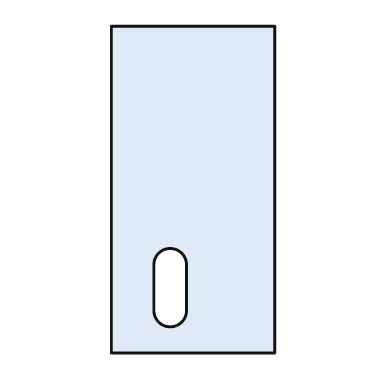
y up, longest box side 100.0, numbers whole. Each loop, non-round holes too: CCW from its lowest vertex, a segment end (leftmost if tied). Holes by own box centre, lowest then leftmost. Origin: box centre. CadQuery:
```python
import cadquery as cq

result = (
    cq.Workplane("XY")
    .moveTo(-25.0, -50.0)
    .lineTo(25.0, -50.0)
    .lineTo(25.0, 50.0)
    .lineTo(-25.0, 50.0)
    .close()
    .moveTo(-12.0, -37.0)
    .threePointArc((-7.0, -42.0), (-2.0, -37.0))
    .lineTo(-2.0, -23.0)
    .threePointArc((-7.0, -18.0), (-12.0, -23.0))
    .close()
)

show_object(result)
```